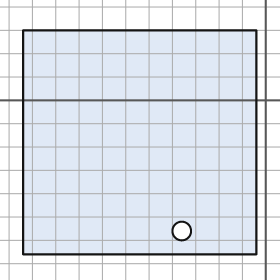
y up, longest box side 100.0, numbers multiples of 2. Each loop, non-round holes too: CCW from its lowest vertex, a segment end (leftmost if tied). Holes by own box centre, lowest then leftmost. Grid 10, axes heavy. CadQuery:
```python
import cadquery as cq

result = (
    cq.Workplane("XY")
    .moveTo(-104.0, -66.0)
    .lineTo(-4.0, -66.0)
    .lineTo(-4.0, 30.0)
    .lineTo(-104.0, 30.0)
    .close()
    .moveTo(-36.0, -56.0)
    .circle(4.0)
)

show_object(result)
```